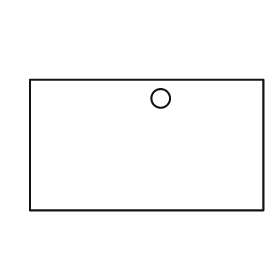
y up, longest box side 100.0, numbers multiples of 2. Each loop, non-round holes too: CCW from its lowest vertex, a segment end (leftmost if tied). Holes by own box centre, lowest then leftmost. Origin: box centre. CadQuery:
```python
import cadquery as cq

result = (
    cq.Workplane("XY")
    .moveTo(-50.0, -28.0)
    .lineTo(50.0, -28.0)
    .lineTo(50.0, 28.0)
    .lineTo(-50.0, 28.0)
    .close()
    .moveTo(6.0, 20.0)
    .circle(4.0)
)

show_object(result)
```